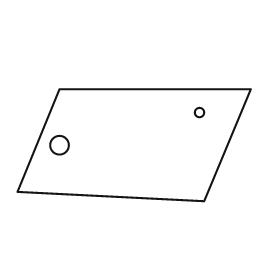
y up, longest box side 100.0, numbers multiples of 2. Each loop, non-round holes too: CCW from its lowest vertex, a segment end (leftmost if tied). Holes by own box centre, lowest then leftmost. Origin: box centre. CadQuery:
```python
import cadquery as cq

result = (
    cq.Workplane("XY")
    .moveTo(30.0, -24.0)
    .lineTo(50.0, 24.0)
    .lineTo(-32.0, 24.0)
    .lineTo(-50.0, -20.0)
    .close()
    .moveTo(-32.0, 0.0)
    .circle(4.0)
    .moveTo(28.0, 14.0)
    .circle(2.0)
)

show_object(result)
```